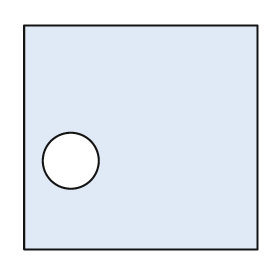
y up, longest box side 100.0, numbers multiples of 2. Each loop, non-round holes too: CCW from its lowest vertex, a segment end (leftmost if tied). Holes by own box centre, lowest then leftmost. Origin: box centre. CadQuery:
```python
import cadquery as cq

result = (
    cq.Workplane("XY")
    .moveTo(-50.0, -48.0)
    .lineTo(50.0, -48.0)
    .lineTo(50.0, 48.0)
    .lineTo(-50.0, 48.0)
    .close()
    .moveTo(-30.0, -10.0)
    .circle(12.0)
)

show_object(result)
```